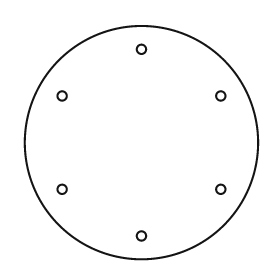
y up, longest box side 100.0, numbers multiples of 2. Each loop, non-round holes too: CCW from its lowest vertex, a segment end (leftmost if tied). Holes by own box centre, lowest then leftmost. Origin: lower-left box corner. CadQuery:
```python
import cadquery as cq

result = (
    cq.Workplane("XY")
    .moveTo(50.0, 50.0)
    .circle(50.0)
    .moveTo(50.0, 10.0)
    .circle(2.0)
    .moveTo(16.0, 30.0)
    .circle(2.0)
    .moveTo(84.0, 30.0)
    .circle(2.0)
    .moveTo(16.0, 70.0)
    .circle(2.0)
    .moveTo(84.0, 70.0)
    .circle(2.0)
    .moveTo(50.0, 90.0)
    .circle(2.0)
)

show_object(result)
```